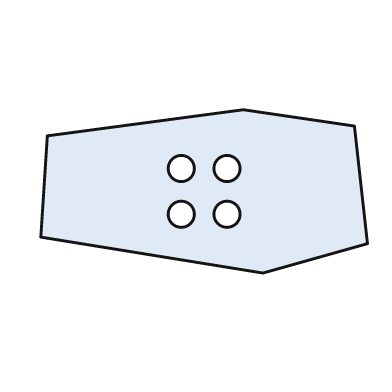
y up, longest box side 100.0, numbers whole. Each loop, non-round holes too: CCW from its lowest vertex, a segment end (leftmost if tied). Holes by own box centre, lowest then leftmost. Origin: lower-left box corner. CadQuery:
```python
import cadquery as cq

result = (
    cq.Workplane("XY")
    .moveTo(68.0, 0.0)
    .lineTo(100.0, 9.0)
    .lineTo(96.0, 45.0)
    .lineTo(62.0, 50.0)
    .lineTo(2.0, 42.0)
    .lineTo(0.0, 11.0)
    .close()
    .moveTo(43.0, 18.0)
    .circle(4.0)
    .moveTo(57.0, 18.0)
    .circle(4.0)
    .moveTo(43.0, 32.0)
    .circle(4.0)
    .moveTo(57.0, 32.0)
    .circle(4.0)
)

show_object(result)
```